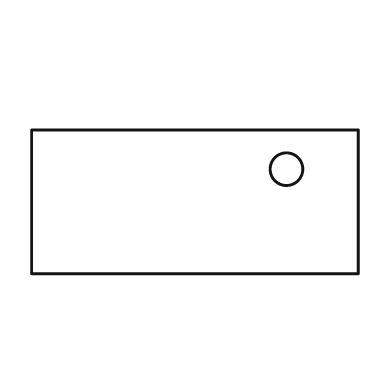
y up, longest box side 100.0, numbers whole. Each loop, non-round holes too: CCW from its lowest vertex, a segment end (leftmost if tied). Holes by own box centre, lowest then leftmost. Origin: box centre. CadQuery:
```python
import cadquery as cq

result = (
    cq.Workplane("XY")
    .moveTo(-50.0, -22.0)
    .lineTo(50.0, -22.0)
    .lineTo(50.0, 22.0)
    .lineTo(-50.0, 22.0)
    .close()
    .moveTo(28.0, 10.0)
    .circle(5.0)
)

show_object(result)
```